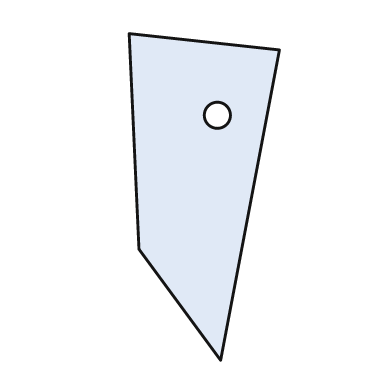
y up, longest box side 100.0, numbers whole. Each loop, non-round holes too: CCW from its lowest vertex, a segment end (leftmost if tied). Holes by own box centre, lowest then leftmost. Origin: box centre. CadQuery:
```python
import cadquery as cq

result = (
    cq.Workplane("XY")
    .moveTo(5.0, -50.0)
    .lineTo(23.0, 45.0)
    .lineTo(-23.0, 50.0)
    .lineTo(-20.0, -16.0)
    .close()
    .moveTo(4.0, 25.0)
    .circle(4.0)
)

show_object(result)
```